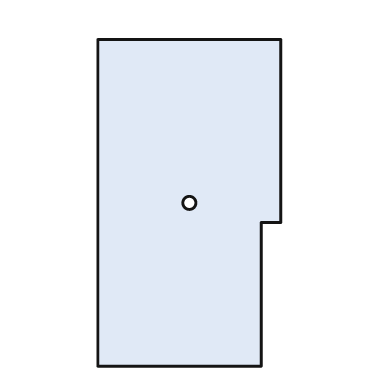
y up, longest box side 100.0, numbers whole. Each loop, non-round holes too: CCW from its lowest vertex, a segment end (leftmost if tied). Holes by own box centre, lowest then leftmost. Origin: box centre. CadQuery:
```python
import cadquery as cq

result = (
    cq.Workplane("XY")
    .moveTo(-28.0, -50.0)
    .lineTo(22.0, -50.0)
    .lineTo(22.0, -6.0)
    .lineTo(28.0, -6.0)
    .lineTo(28.0, 50.0)
    .lineTo(-28.0, 50.0)
    .close()
    .moveTo(0.0, 0.0)
    .circle(2.0)
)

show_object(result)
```